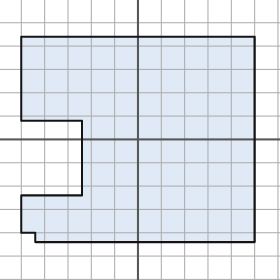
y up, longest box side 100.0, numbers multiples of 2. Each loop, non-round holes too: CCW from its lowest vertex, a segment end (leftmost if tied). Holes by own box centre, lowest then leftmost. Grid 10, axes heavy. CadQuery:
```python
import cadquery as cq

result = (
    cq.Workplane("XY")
    .moveTo(-44.0, -44.0)
    .lineTo(50.0, -44.0)
    .lineTo(50.0, 44.0)
    .lineTo(-50.0, 44.0)
    .lineTo(-50.0, 8.0)
    .lineTo(-24.0, 8.0)
    .lineTo(-24.0, -24.0)
    .lineTo(-50.0, -24.0)
    .lineTo(-50.0, -40.0)
    .lineTo(-44.0, -40.0)
    .close()
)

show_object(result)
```